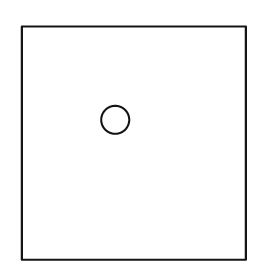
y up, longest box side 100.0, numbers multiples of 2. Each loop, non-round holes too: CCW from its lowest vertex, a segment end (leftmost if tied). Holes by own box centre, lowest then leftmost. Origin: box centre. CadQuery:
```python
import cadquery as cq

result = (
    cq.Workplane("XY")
    .moveTo(-48.0, -50.0)
    .lineTo(48.0, -50.0)
    .lineTo(48.0, 50.0)
    .lineTo(-48.0, 50.0)
    .close()
    .moveTo(-8.0, 10.0)
    .circle(6.0)
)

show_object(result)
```